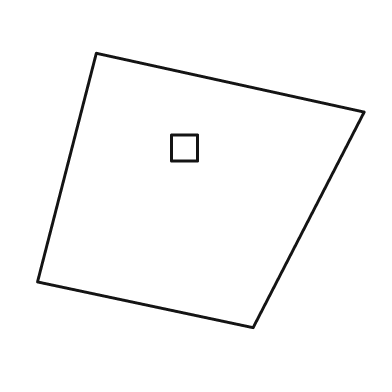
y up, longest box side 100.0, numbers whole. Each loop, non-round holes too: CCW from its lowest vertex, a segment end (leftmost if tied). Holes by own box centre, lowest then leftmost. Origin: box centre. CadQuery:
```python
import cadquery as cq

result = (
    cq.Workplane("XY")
    .moveTo(16.0, -42.0)
    .lineTo(50.0, 24.0)
    .lineTo(-32.0, 42.0)
    .lineTo(-50.0, -28.0)
    .close()
    .moveTo(-9.0, 9.0)
    .lineTo(-1.0, 9.0)
    .lineTo(-1.0, 17.0)
    .lineTo(-9.0, 17.0)
    .close()
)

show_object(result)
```